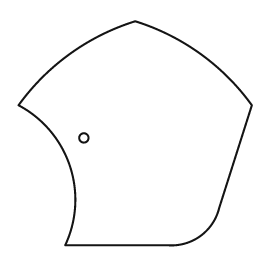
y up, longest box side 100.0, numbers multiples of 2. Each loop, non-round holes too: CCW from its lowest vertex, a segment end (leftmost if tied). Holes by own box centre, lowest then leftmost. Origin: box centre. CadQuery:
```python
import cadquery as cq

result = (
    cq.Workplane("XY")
    .moveTo(-30.0, -48.0)
    .lineTo(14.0, -48.0)
    .threePointArc((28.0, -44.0), (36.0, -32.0))
    .lineTo(50.0, 12.0)
    .threePointArc((28.0, 34.0), (0.0, 48.0))
    .threePointArc((-28.0, 34.0), (-50.0, 12.0))
    .threePointArc((-28.0, -14.0), (-30.0, -48.0))
    .close()
    .moveTo(-22.0, -2.0)
    .circle(2.0)
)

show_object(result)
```